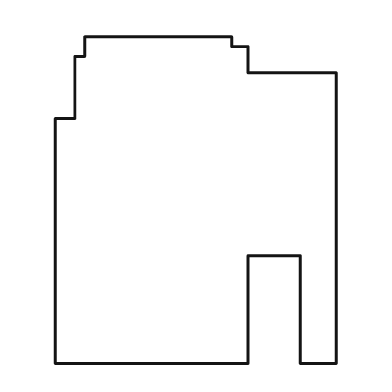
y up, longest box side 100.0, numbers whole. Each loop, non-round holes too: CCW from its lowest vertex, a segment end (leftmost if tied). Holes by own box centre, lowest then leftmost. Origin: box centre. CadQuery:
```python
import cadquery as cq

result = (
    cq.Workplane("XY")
    .moveTo(-43.0, -50.0)
    .lineTo(16.0, -50.0)
    .lineTo(16.0, -17.0)
    .lineTo(32.0, -17.0)
    .lineTo(32.0, -50.0)
    .lineTo(43.0, -50.0)
    .lineTo(43.0, 39.0)
    .lineTo(16.0, 39.0)
    .lineTo(16.0, 47.0)
    .lineTo(11.0, 47.0)
    .lineTo(11.0, 50.0)
    .lineTo(-34.0, 50.0)
    .lineTo(-34.0, 44.0)
    .lineTo(-37.0, 44.0)
    .lineTo(-37.0, 25.0)
    .lineTo(-43.0, 25.0)
    .close()
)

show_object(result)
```